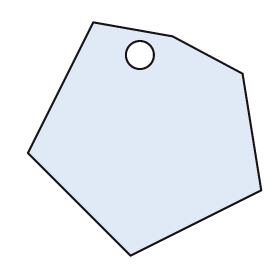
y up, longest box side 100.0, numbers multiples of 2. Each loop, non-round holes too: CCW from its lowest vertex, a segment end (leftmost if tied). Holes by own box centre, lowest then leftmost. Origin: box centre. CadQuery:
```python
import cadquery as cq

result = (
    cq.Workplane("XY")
    .moveTo(-6.0, -50.0)
    .lineTo(50.0, -22.0)
    .lineTo(42.0, 28.0)
    .lineTo(12.0, 44.0)
    .lineTo(-22.0, 50.0)
    .lineTo(-50.0, -6.0)
    .close()
    .moveTo(-2.0, 36.0)
    .circle(6.0)
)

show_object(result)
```